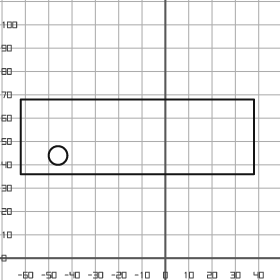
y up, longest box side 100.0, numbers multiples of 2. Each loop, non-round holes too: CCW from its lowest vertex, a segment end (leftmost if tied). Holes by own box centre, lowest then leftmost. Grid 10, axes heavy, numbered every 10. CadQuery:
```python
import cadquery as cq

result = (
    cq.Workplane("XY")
    .moveTo(-62.0, 36.0)
    .lineTo(38.0, 36.0)
    .lineTo(38.0, 68.0)
    .lineTo(-62.0, 68.0)
    .close()
    .moveTo(-46.0, 44.0)
    .circle(4.0)
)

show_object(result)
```